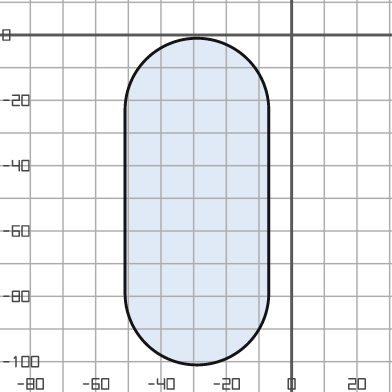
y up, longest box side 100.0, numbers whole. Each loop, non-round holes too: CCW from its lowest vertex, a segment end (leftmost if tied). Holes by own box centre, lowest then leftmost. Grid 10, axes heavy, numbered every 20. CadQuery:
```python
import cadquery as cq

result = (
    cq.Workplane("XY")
    .moveTo(-51.0, -79.0)
    .threePointArc((-29.0, -101.0), (-7.0, -79.0))
    .lineTo(-7.0, -23.0)
    .threePointArc((-29.0, -1.0), (-51.0, -23.0))
    .close()
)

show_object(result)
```